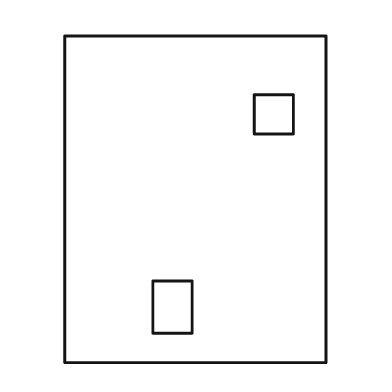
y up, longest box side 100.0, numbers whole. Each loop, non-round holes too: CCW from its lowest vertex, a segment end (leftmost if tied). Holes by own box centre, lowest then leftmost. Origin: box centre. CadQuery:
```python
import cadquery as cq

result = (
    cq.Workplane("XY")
    .moveTo(-40.0, -50.0)
    .lineTo(40.0, -50.0)
    .lineTo(40.0, 50.0)
    .lineTo(-40.0, 50.0)
    .close()
    .moveTo(-13.0, -41.0)
    .lineTo(-1.0, -41.0)
    .lineTo(-1.0, -25.0)
    .lineTo(-13.0, -25.0)
    .close()
    .moveTo(18.0, 20.0)
    .lineTo(30.0, 20.0)
    .lineTo(30.0, 32.0)
    .lineTo(18.0, 32.0)
    .close()
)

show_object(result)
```